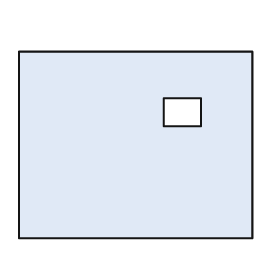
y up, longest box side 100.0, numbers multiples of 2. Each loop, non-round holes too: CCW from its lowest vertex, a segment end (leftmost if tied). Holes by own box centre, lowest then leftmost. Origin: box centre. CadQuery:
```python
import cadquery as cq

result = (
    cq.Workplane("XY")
    .moveTo(-50.0, -40.0)
    .lineTo(50.0, -40.0)
    .lineTo(50.0, 40.0)
    .lineTo(-50.0, 40.0)
    .close()
    .moveTo(12.0, 8.0)
    .lineTo(28.0, 8.0)
    .lineTo(28.0, 20.0)
    .lineTo(12.0, 20.0)
    .close()
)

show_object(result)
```